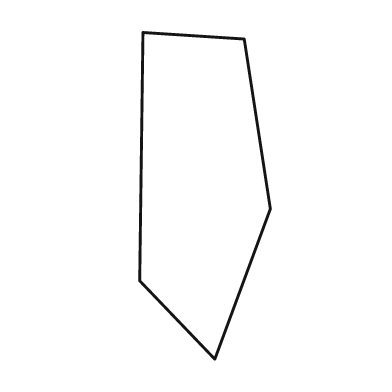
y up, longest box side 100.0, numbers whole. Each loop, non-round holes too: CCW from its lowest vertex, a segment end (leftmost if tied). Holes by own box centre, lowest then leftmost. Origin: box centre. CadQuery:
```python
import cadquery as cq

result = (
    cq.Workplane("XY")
    .moveTo(3.0, -50.0)
    .lineTo(20.0, -4.0)
    .lineTo(12.0, 48.0)
    .lineTo(-19.0, 50.0)
    .lineTo(-20.0, -26.0)
    .close()
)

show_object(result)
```